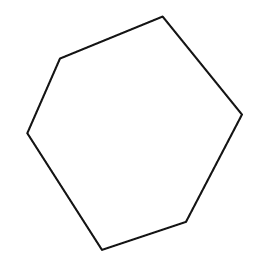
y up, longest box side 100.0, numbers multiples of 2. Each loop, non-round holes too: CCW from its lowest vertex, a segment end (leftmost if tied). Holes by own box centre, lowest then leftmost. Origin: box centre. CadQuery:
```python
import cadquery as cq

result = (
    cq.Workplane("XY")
    .moveTo(-14.0, -50.0)
    .lineTo(22.0, -38.0)
    .lineTo(46.0, 8.0)
    .lineTo(12.0, 50.0)
    .lineTo(-32.0, 32.0)
    .lineTo(-46.0, 0.0)
    .close()
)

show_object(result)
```